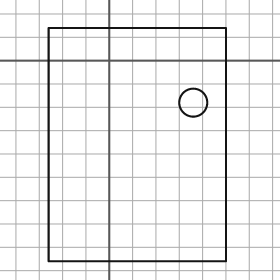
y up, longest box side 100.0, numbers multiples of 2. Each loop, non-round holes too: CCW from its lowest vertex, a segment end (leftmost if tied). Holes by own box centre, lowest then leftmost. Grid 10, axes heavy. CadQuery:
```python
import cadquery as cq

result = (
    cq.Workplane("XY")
    .moveTo(-26.0, -86.0)
    .lineTo(50.0, -86.0)
    .lineTo(50.0, 14.0)
    .lineTo(-26.0, 14.0)
    .close()
    .moveTo(36.0, -18.0)
    .circle(6.0)
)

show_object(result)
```